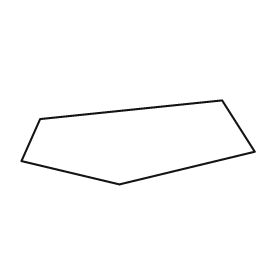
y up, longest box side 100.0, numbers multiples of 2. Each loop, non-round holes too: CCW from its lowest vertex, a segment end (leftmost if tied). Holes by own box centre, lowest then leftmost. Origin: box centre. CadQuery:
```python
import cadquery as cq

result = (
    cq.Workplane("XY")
    .moveTo(-8.0, -18.0)
    .lineTo(50.0, -4.0)
    .lineTo(36.0, 18.0)
    .lineTo(-42.0, 10.0)
    .lineTo(-50.0, -8.0)
    .close()
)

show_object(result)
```